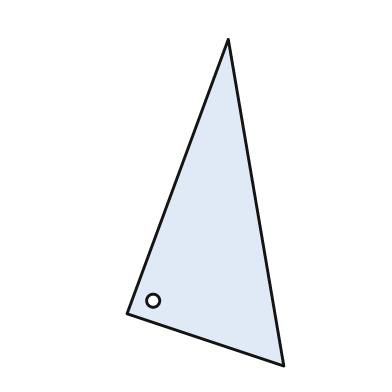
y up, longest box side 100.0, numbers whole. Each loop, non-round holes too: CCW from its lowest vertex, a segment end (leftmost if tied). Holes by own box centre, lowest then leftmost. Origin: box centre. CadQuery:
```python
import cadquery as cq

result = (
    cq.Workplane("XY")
    .moveTo(24.0, -50.0)
    .lineTo(7.0, 50.0)
    .lineTo(-24.0, -34.0)
    .close()
    .moveTo(-16.0, -30.0)
    .circle(2.0)
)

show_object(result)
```